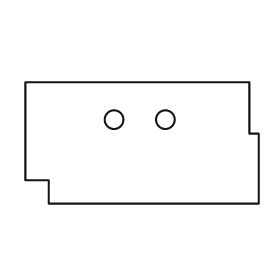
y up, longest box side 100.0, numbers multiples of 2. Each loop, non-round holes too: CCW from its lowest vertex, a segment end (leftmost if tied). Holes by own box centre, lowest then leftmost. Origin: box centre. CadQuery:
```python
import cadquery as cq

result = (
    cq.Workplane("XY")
    .moveTo(-40.0, -26.0)
    .lineTo(50.0, -26.0)
    .lineTo(50.0, 4.0)
    .lineTo(46.0, 4.0)
    .lineTo(46.0, 26.0)
    .lineTo(-50.0, 26.0)
    .lineTo(-50.0, -16.0)
    .lineTo(-40.0, -16.0)
    .close()
    .moveTo(-12.0, 10.0)
    .circle(4.0)
    .moveTo(10.0, 10.0)
    .circle(4.0)
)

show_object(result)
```